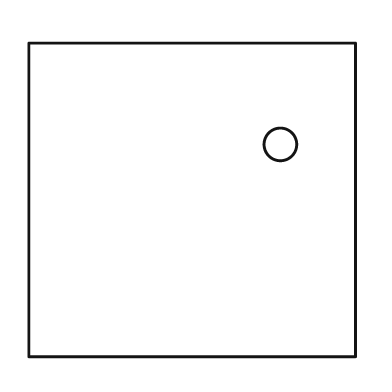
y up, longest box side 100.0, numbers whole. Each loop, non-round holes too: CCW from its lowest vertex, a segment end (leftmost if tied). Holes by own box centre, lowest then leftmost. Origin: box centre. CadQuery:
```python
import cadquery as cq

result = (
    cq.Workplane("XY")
    .moveTo(-50.0, -48.0)
    .lineTo(50.0, -48.0)
    .lineTo(50.0, 48.0)
    .lineTo(-50.0, 48.0)
    .close()
    .moveTo(27.0, 17.0)
    .circle(5.0)
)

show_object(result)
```